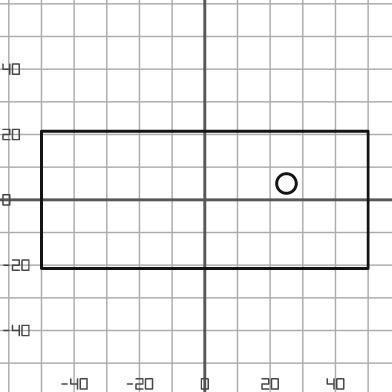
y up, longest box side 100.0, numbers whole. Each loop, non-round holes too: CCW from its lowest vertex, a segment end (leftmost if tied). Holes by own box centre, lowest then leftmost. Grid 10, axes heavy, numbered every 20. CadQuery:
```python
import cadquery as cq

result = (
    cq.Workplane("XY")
    .moveTo(-50.0, -21.0)
    .lineTo(50.0, -21.0)
    .lineTo(50.0, 21.0)
    .lineTo(-50.0, 21.0)
    .close()
    .moveTo(25.0, 5.0)
    .circle(3.0)
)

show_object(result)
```